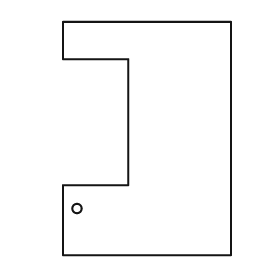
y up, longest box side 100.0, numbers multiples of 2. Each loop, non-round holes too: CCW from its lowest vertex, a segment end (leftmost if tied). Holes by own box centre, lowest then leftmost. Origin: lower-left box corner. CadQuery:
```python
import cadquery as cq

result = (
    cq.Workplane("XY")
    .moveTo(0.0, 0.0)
    .lineTo(72.0, 0.0)
    .lineTo(72.0, 100.0)
    .lineTo(0.0, 100.0)
    .lineTo(0.0, 84.0)
    .lineTo(28.0, 84.0)
    .lineTo(28.0, 30.0)
    .lineTo(0.0, 30.0)
    .close()
    .moveTo(6.0, 20.0)
    .circle(2.0)
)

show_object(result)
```